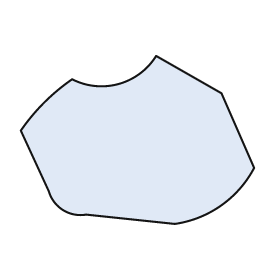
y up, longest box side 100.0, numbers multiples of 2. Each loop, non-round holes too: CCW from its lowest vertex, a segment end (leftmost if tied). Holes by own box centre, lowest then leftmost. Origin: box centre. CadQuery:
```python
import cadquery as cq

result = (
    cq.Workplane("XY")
    .moveTo(16.0, -36.0)
    .threePointArc((36.0, -28.0), (50.0, -12.0))
    .lineTo(36.0, 20.0)
    .lineTo(8.0, 36.0)
    .threePointArc((-8.0, 24.0), (-28.0, 26.0))
    .threePointArc((-40.0, 16.0), (-50.0, 4.0))
    .lineTo(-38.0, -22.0)
    .threePointArc((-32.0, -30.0), (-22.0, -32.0))
    .close()
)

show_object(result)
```